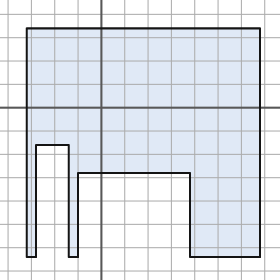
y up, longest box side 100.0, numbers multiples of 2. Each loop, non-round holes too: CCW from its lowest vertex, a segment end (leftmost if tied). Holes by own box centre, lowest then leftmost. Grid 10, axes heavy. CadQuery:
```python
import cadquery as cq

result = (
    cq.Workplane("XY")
    .moveTo(-32.0, -64.0)
    .lineTo(-28.0, -64.0)
    .lineTo(-28.0, -16.0)
    .lineTo(-14.0, -16.0)
    .lineTo(-14.0, -64.0)
    .lineTo(-10.0, -64.0)
    .lineTo(-10.0, -28.0)
    .lineTo(38.0, -28.0)
    .lineTo(38.0, -64.0)
    .lineTo(68.0, -64.0)
    .lineTo(68.0, 34.0)
    .lineTo(-32.0, 34.0)
    .close()
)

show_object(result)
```